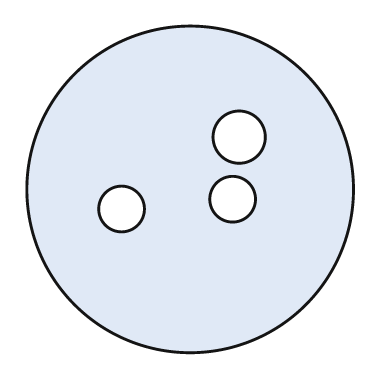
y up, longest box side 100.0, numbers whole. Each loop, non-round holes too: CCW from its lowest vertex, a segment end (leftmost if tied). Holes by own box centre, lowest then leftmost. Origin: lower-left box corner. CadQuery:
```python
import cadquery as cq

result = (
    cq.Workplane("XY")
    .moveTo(50.0, 50.0)
    .circle(50.0)
    .moveTo(29.0, 44.0)
    .circle(7.0)
    .moveTo(63.0, 47.0)
    .circle(7.0)
    .moveTo(65.0, 66.0)
    .circle(8.0)
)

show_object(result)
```